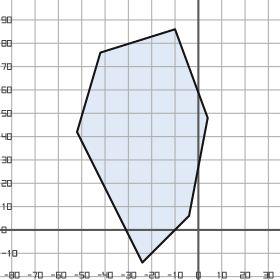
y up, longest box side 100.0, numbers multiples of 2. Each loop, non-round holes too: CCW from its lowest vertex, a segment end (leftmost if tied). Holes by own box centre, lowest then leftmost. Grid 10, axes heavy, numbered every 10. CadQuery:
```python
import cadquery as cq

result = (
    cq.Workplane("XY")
    .moveTo(-24.0, -14.0)
    .lineTo(-4.0, 6.0)
    .lineTo(4.0, 48.0)
    .lineTo(-10.0, 86.0)
    .lineTo(-42.0, 76.0)
    .lineTo(-52.0, 42.0)
    .close()
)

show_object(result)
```